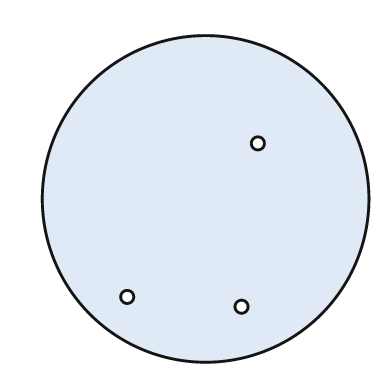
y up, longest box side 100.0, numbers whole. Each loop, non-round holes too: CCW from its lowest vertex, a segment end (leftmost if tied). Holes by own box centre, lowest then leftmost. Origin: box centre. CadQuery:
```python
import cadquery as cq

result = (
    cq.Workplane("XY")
    .moveTo(0.0, 0.0)
    .circle(50.0)
    .moveTo(11.0, -33.0)
    .circle(2.0)
    .moveTo(-24.0, -30.0)
    .circle(2.0)
    .moveTo(16.0, 17.0)
    .circle(2.0)
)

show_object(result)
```